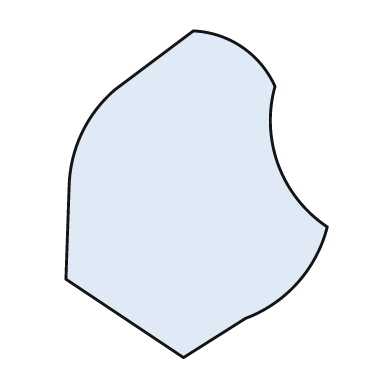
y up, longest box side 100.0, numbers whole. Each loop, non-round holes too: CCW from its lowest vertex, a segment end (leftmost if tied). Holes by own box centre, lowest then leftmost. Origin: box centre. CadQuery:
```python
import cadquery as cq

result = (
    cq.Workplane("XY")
    .moveTo(-4.0, -50.0)
    .lineTo(15.0, -38.0)
    .threePointArc((31.0, -27.0), (40.0, -10.0))
    .threePointArc((25.0, 9.0), (24.0, 33.0))
    .threePointArc((14.0, 45.0), (-1.0, 50.0))
    .lineTo(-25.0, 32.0)
    .threePointArc((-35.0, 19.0), (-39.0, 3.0))
    .lineTo(-40.0, -26.0)
    .close()
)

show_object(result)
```